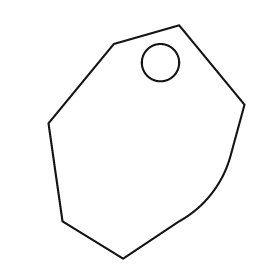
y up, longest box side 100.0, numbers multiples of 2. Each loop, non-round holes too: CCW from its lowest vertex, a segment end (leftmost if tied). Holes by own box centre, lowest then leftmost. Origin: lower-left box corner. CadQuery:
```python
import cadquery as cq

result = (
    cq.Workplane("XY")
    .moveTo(32.0, 0.0)
    .lineTo(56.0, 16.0)
    .threePointArc((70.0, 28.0), (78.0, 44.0))
    .lineTo(84.0, 66.0)
    .lineTo(56.0, 100.0)
    .lineTo(28.0, 92.0)
    .lineTo(0.0, 58.0)
    .lineTo(6.0, 16.0)
    .close()
    .moveTo(48.0, 84.0)
    .circle(8.0)
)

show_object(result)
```